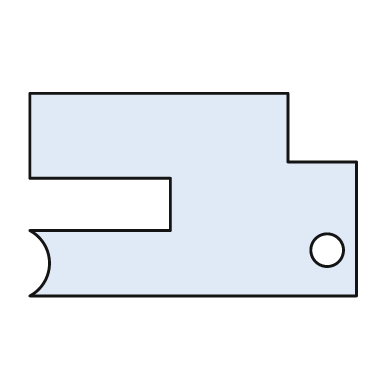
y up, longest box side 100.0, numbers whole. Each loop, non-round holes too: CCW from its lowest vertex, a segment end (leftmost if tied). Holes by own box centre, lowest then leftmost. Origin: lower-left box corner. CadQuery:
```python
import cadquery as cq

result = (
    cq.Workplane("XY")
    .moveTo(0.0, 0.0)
    .lineTo(100.0, 0.0)
    .lineTo(100.0, 41.0)
    .lineTo(79.0, 41.0)
    .lineTo(79.0, 62.0)
    .lineTo(0.0, 62.0)
    .lineTo(0.0, 36.0)
    .lineTo(43.0, 36.0)
    .lineTo(43.0, 20.0)
    .lineTo(0.0, 20.0)
    .threePointArc((6.0, 10.0), (0.0, 0.0))
    .close()
    .moveTo(91.0, 14.0)
    .circle(5.0)
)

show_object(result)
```